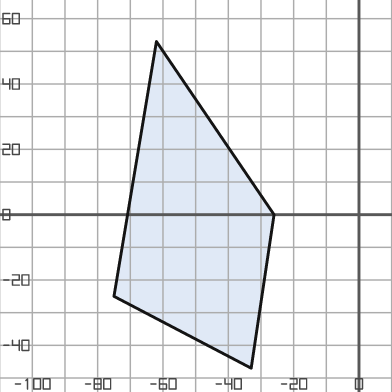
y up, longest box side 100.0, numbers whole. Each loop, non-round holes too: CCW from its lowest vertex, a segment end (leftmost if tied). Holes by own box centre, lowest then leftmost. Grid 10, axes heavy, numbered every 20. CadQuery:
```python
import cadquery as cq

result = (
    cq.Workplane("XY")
    .moveTo(-33.0, -47.0)
    .lineTo(-26.0, 0.0)
    .lineTo(-62.0, 53.0)
    .lineTo(-75.0, -25.0)
    .close()
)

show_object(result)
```